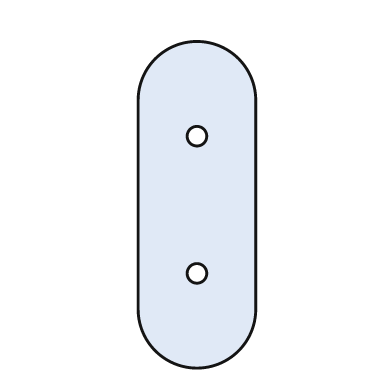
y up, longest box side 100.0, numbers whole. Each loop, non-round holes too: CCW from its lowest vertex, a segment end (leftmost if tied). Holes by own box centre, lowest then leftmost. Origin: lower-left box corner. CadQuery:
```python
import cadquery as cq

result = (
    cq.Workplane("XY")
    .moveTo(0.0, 18.0)
    .threePointArc((18.0, 0.0), (36.0, 18.0))
    .lineTo(36.0, 82.0)
    .threePointArc((18.0, 100.0), (0.0, 82.0))
    .close()
    .moveTo(18.0, 29.0)
    .circle(3.0)
    .moveTo(18.0, 71.0)
    .circle(3.0)
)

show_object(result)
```